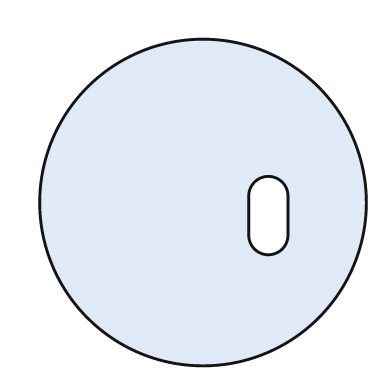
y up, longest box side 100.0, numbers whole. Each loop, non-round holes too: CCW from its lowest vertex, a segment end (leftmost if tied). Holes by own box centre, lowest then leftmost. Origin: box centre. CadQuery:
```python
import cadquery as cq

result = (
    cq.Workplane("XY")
    .moveTo(0.0, 0.0)
    .circle(50.0)
    .moveTo(14.0, -10.0)
    .threePointArc((20.0, -16.0), (26.0, -10.0))
    .lineTo(26.0, 2.0)
    .threePointArc((20.0, 8.0), (14.0, 2.0))
    .close()
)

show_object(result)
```